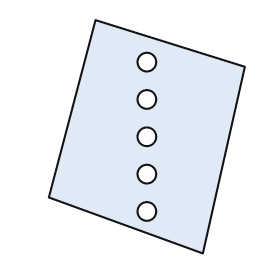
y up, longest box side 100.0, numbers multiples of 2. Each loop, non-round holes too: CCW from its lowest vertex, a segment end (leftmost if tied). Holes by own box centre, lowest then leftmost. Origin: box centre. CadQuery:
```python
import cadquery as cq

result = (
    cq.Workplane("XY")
    .moveTo(24.0, -50.0)
    .lineTo(42.0, 30.0)
    .lineTo(-22.0, 50.0)
    .lineTo(-42.0, -26.0)
    .close()
    .moveTo(0.0, -32.0)
    .circle(4.0)
    .moveTo(0.0, -16.0)
    .circle(4.0)
    .moveTo(0.0, 0.0)
    .circle(4.0)
    .moveTo(0.0, 16.0)
    .circle(4.0)
    .moveTo(0.0, 32.0)
    .circle(4.0)
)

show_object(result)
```